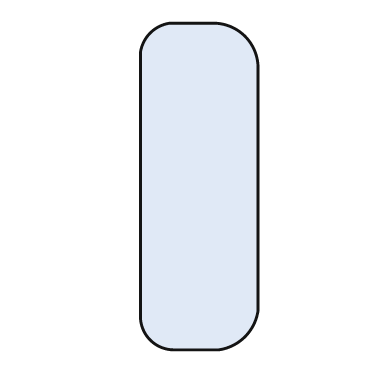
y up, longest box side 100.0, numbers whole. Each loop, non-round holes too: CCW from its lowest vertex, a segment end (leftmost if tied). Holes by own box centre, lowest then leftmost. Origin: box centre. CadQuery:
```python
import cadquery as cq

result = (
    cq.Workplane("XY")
    .moveTo(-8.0, -50.0)
    .lineTo(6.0, -50.0)
    .threePointArc((14.0, -46.0), (18.0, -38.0))
    .lineTo(18.0, 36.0)
    .threePointArc((14.0, 46.0), (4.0, 50.0))
    .lineTo(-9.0, 50.0)
    .threePointArc((-15.0, 47.0), (-18.0, 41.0))
    .lineTo(-18.0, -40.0)
    .threePointArc((-15.0, -47.0), (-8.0, -50.0))
    .close()
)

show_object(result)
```